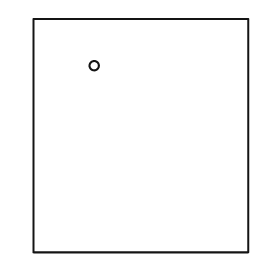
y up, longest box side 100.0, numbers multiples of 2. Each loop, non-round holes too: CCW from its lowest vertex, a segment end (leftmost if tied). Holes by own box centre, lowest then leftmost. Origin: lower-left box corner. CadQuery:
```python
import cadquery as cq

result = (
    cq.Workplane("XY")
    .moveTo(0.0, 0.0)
    .lineTo(92.0, 0.0)
    .lineTo(92.0, 100.0)
    .lineTo(0.0, 100.0)
    .close()
    .moveTo(26.0, 80.0)
    .circle(2.0)
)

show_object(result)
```